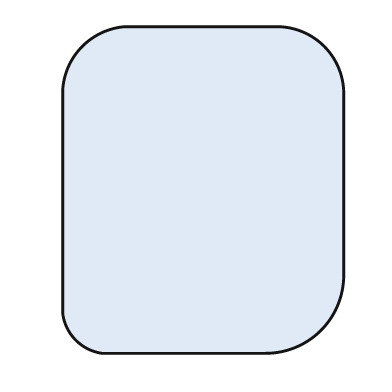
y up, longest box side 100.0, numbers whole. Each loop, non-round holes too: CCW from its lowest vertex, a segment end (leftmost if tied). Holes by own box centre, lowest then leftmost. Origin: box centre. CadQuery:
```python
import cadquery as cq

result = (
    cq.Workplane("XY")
    .moveTo(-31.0, -50.0)
    .lineTo(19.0, -50.0)
    .threePointArc((36.0, -43.0), (43.0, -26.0))
    .lineTo(43.0, 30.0)
    .threePointArc((37.0, 44.0), (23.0, 50.0))
    .lineTo(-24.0, 50.0)
    .threePointArc((-37.0, 44.0), (-43.0, 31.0))
    .lineTo(-43.0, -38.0)
    .threePointArc((-39.0, -46.0), (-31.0, -50.0))
    .close()
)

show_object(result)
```